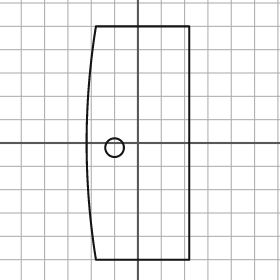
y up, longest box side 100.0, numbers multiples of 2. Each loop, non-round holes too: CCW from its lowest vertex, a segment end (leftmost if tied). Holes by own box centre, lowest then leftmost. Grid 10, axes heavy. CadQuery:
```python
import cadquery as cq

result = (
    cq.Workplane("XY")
    .moveTo(-18.0, -50.0)
    .lineTo(22.0, -50.0)
    .lineTo(22.0, 50.0)
    .lineTo(-18.0, 50.0)
    .threePointArc((-22.0, 0.0), (-18.0, -50.0))
    .close()
    .moveTo(-10.0, -2.0)
    .circle(4.0)
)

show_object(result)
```